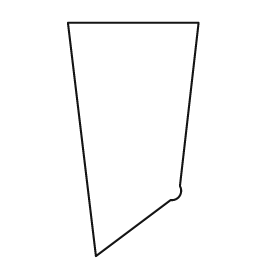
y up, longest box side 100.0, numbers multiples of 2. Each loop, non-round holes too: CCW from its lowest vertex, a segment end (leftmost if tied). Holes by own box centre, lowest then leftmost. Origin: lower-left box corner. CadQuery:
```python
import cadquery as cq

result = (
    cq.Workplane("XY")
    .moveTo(12.0, 0.0)
    .lineTo(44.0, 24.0)
    .threePointArc((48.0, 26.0), (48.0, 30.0))
    .lineTo(56.0, 100.0)
    .lineTo(0.0, 100.0)
    .close()
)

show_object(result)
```